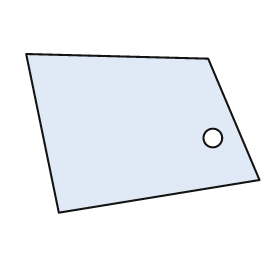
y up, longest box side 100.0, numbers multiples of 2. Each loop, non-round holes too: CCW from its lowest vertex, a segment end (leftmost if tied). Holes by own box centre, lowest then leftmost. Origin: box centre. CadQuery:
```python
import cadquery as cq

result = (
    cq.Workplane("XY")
    .moveTo(-36.0, -34.0)
    .lineTo(50.0, -20.0)
    .lineTo(28.0, 32.0)
    .lineTo(-50.0, 34.0)
    .close()
    .moveTo(30.0, -2.0)
    .circle(4.0)
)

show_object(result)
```